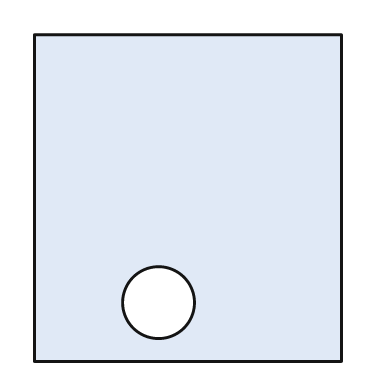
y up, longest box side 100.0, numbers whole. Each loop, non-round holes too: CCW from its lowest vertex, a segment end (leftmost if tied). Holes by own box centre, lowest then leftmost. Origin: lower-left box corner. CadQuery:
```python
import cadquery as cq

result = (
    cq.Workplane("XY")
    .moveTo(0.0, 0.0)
    .lineTo(94.0, 0.0)
    .lineTo(94.0, 100.0)
    .lineTo(0.0, 100.0)
    .close()
    .moveTo(38.0, 18.0)
    .circle(11.0)
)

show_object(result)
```